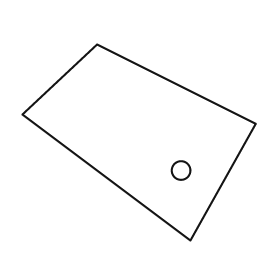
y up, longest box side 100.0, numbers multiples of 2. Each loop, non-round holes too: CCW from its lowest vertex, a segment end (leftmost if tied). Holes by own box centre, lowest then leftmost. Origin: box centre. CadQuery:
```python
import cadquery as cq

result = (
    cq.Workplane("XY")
    .moveTo(22.0, -42.0)
    .lineTo(50.0, 8.0)
    .lineTo(-18.0, 42.0)
    .lineTo(-50.0, 12.0)
    .close()
    .moveTo(18.0, -12.0)
    .circle(4.0)
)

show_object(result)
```